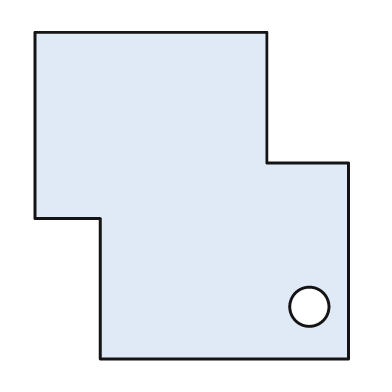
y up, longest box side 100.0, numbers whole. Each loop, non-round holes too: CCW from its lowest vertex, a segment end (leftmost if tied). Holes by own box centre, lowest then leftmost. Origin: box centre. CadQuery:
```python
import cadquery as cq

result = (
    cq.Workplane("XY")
    .moveTo(-28.0, -50.0)
    .lineTo(48.0, -50.0)
    .lineTo(48.0, 10.0)
    .lineTo(23.0, 10.0)
    .lineTo(23.0, 50.0)
    .lineTo(-48.0, 50.0)
    .lineTo(-48.0, -7.0)
    .lineTo(-28.0, -7.0)
    .close()
    .moveTo(36.0, -34.0)
    .circle(6.0)
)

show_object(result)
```